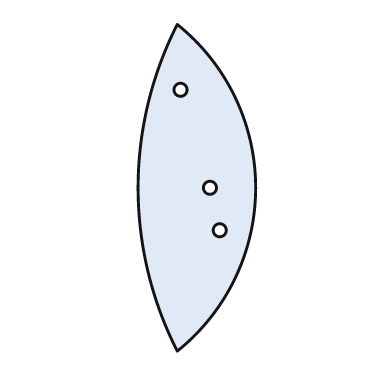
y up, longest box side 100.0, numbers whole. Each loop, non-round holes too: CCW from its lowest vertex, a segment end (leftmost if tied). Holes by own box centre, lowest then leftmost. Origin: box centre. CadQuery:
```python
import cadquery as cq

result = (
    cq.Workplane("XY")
    .moveTo(-6.0, -50.0)
    .threePointArc((18.0, 0.0), (-6.0, 50.0))
    .threePointArc((-18.0, 0.0), (-6.0, -50.0))
    .close()
    .moveTo(7.0, -13.0)
    .circle(2.0)
    .moveTo(4.0, 0.0)
    .circle(2.0)
    .moveTo(-5.0, 30.0)
    .circle(2.0)
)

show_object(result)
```